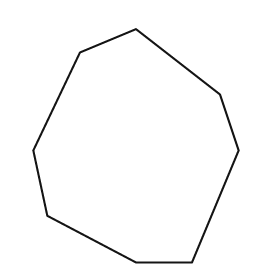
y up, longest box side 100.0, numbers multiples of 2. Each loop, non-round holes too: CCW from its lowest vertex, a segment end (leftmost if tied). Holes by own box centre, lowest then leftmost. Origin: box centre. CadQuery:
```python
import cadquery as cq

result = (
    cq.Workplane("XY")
    .moveTo(0.0, -50.0)
    .lineTo(24.0, -50.0)
    .lineTo(44.0, -2.0)
    .lineTo(36.0, 22.0)
    .lineTo(0.0, 50.0)
    .lineTo(-24.0, 40.0)
    .lineTo(-44.0, -2.0)
    .lineTo(-38.0, -30.0)
    .close()
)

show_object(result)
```